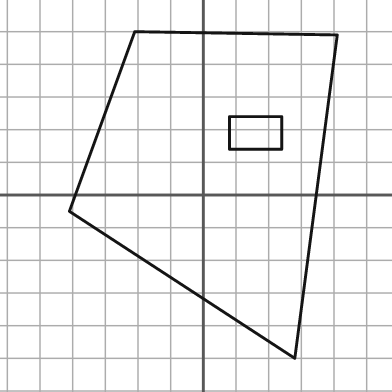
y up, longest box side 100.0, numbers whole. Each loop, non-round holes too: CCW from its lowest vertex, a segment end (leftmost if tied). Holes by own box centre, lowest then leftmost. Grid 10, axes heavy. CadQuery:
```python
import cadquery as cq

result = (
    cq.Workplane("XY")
    .moveTo(28.0, -50.0)
    .lineTo(41.0, 49.0)
    .lineTo(-21.0, 50.0)
    .lineTo(-41.0, -5.0)
    .close()
    .moveTo(8.0, 14.0)
    .lineTo(24.0, 14.0)
    .lineTo(24.0, 24.0)
    .lineTo(8.0, 24.0)
    .close()
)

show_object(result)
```